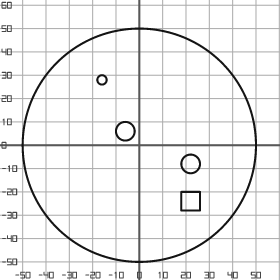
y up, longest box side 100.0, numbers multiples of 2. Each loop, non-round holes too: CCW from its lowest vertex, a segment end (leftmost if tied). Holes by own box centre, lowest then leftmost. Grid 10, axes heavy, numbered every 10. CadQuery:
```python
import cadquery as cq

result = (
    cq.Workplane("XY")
    .moveTo(0.0, 0.0)
    .circle(50.0)
    .moveTo(18.0, -28.0)
    .lineTo(26.0, -28.0)
    .lineTo(26.0, -20.0)
    .lineTo(18.0, -20.0)
    .close()
    .moveTo(22.0, -8.0)
    .circle(4.0)
    .moveTo(-6.0, 6.0)
    .circle(4.0)
    .moveTo(-16.0, 28.0)
    .circle(2.0)
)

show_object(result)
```